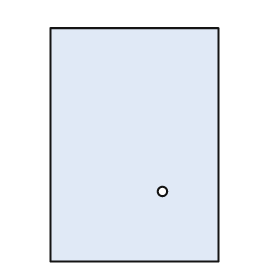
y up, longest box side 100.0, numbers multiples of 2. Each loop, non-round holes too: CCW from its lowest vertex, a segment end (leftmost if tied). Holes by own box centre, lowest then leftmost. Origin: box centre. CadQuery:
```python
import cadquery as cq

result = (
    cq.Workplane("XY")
    .moveTo(-36.0, -50.0)
    .lineTo(36.0, -50.0)
    .lineTo(36.0, 50.0)
    .lineTo(-36.0, 50.0)
    .close()
    .moveTo(12.0, -20.0)
    .circle(2.0)
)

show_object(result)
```